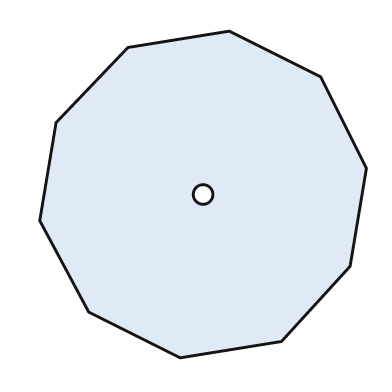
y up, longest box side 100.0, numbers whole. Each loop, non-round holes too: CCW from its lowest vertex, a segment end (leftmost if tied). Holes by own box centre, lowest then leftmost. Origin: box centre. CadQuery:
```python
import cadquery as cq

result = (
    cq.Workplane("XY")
    .moveTo(-7.0, -50.0)
    .lineTo(24.0, -45.0)
    .lineTo(45.0, -22.0)
    .lineTo(50.0, 8.0)
    .lineTo(36.0, 36.0)
    .lineTo(8.0, 50.0)
    .lineTo(-23.0, 45.0)
    .lineTo(-45.0, 22.0)
    .lineTo(-50.0, -8.0)
    .lineTo(-35.0, -36.0)
    .close()
    .moveTo(0.0, 0.0)
    .circle(3.0)
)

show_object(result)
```